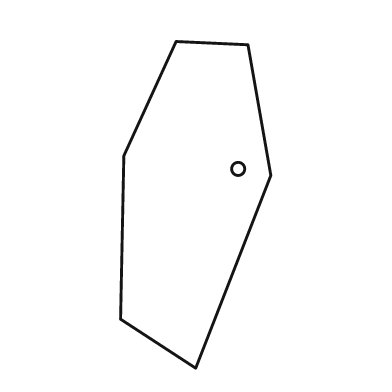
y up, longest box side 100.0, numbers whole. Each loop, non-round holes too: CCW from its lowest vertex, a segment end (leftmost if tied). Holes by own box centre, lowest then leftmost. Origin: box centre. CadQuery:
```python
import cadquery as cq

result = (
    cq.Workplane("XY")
    .moveTo(0.0, -50.0)
    .lineTo(23.0, 9.0)
    .lineTo(16.0, 49.0)
    .lineTo(-6.0, 50.0)
    .lineTo(-22.0, 15.0)
    .lineTo(-23.0, -35.0)
    .close()
    .moveTo(13.0, 11.0)
    .circle(2.0)
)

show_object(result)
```